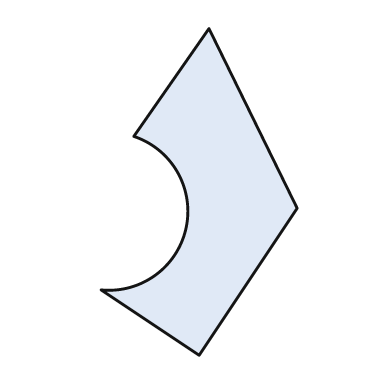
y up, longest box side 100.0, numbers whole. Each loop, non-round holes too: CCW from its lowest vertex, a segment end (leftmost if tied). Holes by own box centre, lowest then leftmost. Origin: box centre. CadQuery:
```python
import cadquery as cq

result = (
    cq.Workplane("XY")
    .moveTo(0.0, -50.0)
    .lineTo(30.0, -5.0)
    .lineTo(3.0, 50.0)
    .lineTo(-20.0, 17.0)
    .threePointArc((-4.0, -11.0), (-30.0, -30.0))
    .close()
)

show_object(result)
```